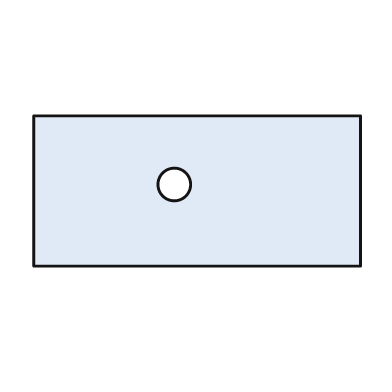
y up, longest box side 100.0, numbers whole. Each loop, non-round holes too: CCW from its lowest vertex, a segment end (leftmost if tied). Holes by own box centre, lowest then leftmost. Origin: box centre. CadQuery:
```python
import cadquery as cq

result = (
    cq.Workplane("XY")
    .moveTo(-50.0, -23.0)
    .lineTo(50.0, -23.0)
    .lineTo(50.0, 23.0)
    .lineTo(-50.0, 23.0)
    .close()
    .moveTo(-7.0, 2.0)
    .circle(5.0)
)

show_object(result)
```